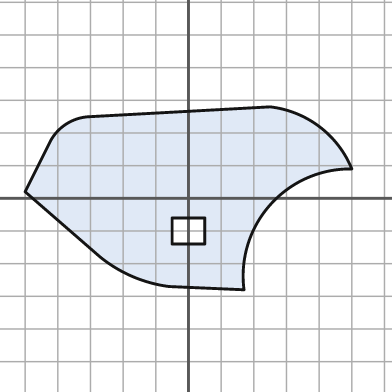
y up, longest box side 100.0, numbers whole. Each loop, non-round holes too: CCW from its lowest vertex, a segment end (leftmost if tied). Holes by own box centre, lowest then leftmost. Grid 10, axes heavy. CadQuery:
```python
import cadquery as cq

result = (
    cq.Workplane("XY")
    .moveTo(17.0, -28.0)
    .threePointArc((25.0, -2.0), (50.0, 9.0))
    .threePointArc((40.0, 22.0), (25.0, 28.0))
    .lineTo(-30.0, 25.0)
    .threePointArc((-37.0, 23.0), (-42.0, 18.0))
    .lineTo(-50.0, 2.0)
    .lineTo(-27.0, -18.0)
    .threePointArc((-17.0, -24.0), (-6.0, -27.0))
    .close()
    .moveTo(-5.0, -14.0)
    .lineTo(5.0, -14.0)
    .lineTo(5.0, -6.0)
    .lineTo(-5.0, -6.0)
    .close()
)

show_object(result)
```